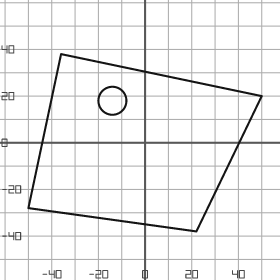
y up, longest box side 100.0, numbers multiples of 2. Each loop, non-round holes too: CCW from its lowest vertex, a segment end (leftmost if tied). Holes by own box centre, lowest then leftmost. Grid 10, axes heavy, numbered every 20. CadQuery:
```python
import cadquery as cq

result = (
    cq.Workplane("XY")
    .moveTo(22.0, -38.0)
    .lineTo(50.0, 20.0)
    .lineTo(-36.0, 38.0)
    .lineTo(-50.0, -28.0)
    .close()
    .moveTo(-14.0, 18.0)
    .circle(6.0)
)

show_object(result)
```